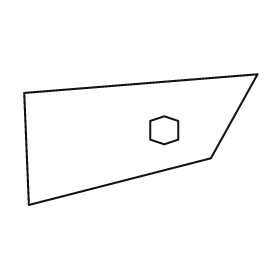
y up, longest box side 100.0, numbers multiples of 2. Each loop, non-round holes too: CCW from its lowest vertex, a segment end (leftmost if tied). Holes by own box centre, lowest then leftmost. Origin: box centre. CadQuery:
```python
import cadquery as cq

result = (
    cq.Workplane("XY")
    .moveTo(-48.0, -28.0)
    .lineTo(30.0, -8.0)
    .lineTo(50.0, 28.0)
    .lineTo(-50.0, 20.0)
    .close()
    .moveTo(10.0, -2.0)
    .lineTo(16.0, 0.0)
    .lineTo(16.0, 8.0)
    .lineTo(10.0, 10.0)
    .lineTo(4.0, 8.0)
    .lineTo(4.0, 0.0)
    .close()
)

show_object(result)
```